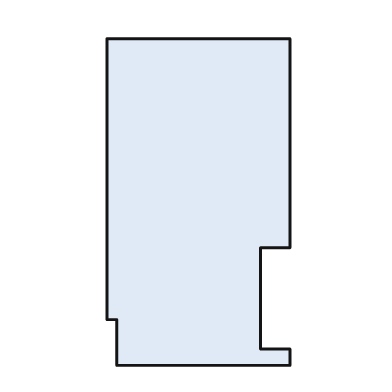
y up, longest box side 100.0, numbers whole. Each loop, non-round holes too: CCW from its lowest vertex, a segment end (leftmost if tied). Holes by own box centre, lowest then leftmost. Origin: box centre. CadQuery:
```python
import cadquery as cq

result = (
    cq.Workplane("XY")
    .moveTo(-25.0, -50.0)
    .lineTo(28.0, -50.0)
    .lineTo(28.0, -45.0)
    .lineTo(19.0, -45.0)
    .lineTo(19.0, -14.0)
    .lineTo(28.0, -14.0)
    .lineTo(28.0, 50.0)
    .lineTo(-28.0, 50.0)
    .lineTo(-28.0, -36.0)
    .lineTo(-25.0, -36.0)
    .close()
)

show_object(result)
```